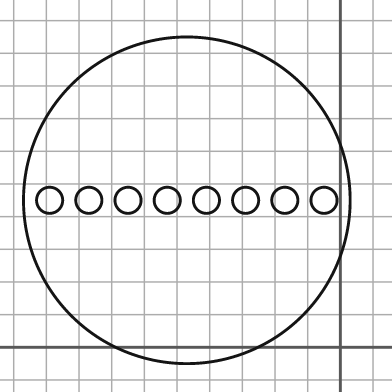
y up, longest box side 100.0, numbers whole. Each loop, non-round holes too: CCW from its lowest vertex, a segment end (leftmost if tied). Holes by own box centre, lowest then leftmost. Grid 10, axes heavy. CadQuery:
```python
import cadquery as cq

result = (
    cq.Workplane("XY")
    .moveTo(-47.0, 45.0)
    .circle(50.0)
    .moveTo(-89.0, 45.0)
    .circle(4.0)
    .moveTo(-77.0, 45.0)
    .circle(4.0)
    .moveTo(-65.0, 45.0)
    .circle(4.0)
    .moveTo(-53.0, 45.0)
    .circle(4.0)
    .moveTo(-41.0, 45.0)
    .circle(4.0)
    .moveTo(-29.0, 45.0)
    .circle(4.0)
    .moveTo(-17.0, 45.0)
    .circle(4.0)
    .moveTo(-5.0, 45.0)
    .circle(4.0)
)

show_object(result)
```